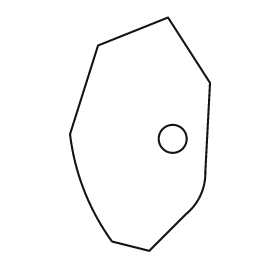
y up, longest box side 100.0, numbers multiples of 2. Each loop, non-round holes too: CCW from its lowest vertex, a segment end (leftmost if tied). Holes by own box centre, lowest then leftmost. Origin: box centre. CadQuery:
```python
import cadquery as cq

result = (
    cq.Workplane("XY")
    .moveTo(4.0, -50.0)
    .lineTo(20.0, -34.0)
    .threePointArc((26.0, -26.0), (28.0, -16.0))
    .lineTo(30.0, 22.0)
    .lineTo(12.0, 50.0)
    .lineTo(-18.0, 38.0)
    .lineTo(-30.0, 0.0)
    .threePointArc((-24.0, -24.0), (-12.0, -46.0))
    .close()
    .moveTo(14.0, -2.0)
    .circle(6.0)
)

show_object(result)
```